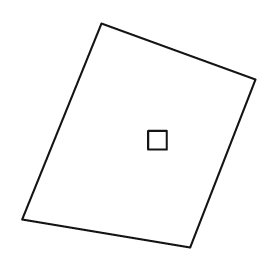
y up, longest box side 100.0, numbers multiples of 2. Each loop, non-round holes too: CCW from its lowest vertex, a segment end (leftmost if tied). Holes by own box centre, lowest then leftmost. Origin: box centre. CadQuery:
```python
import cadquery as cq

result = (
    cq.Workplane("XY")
    .moveTo(22.0, -48.0)
    .lineTo(50.0, 24.0)
    .lineTo(-16.0, 48.0)
    .lineTo(-50.0, -36.0)
    .close()
    .moveTo(4.0, -6.0)
    .lineTo(12.0, -6.0)
    .lineTo(12.0, 2.0)
    .lineTo(4.0, 2.0)
    .close()
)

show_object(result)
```